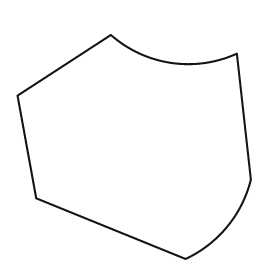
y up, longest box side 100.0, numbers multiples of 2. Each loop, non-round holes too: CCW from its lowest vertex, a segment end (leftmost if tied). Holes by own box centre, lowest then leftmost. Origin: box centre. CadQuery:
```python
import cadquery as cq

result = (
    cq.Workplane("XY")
    .moveTo(22.0, -48.0)
    .threePointArc((40.0, -34.0), (50.0, -14.0))
    .lineTo(44.0, 40.0)
    .threePointArc((16.0, 36.0), (-10.0, 48.0))
    .lineTo(-50.0, 22.0)
    .lineTo(-42.0, -22.0)
    .close()
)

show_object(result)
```